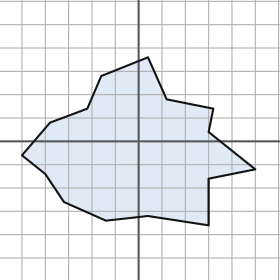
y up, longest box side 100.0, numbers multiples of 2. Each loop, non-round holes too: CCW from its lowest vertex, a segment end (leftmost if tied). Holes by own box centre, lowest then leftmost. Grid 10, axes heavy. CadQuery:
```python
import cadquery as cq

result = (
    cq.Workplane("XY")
    .moveTo(30.0, -36.0)
    .lineTo(30.0, -16.0)
    .lineTo(50.0, -12.0)
    .lineTo(30.0, 4.0)
    .lineTo(32.0, 14.0)
    .lineTo(12.0, 18.0)
    .lineTo(4.0, 36.0)
    .lineTo(-16.0, 28.0)
    .lineTo(-22.0, 14.0)
    .lineTo(-38.0, 8.0)
    .lineTo(-50.0, -6.0)
    .lineTo(-40.0, -14.0)
    .lineTo(-32.0, -26.0)
    .lineTo(-14.0, -34.0)
    .lineTo(4.0, -32.0)
    .close()
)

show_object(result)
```